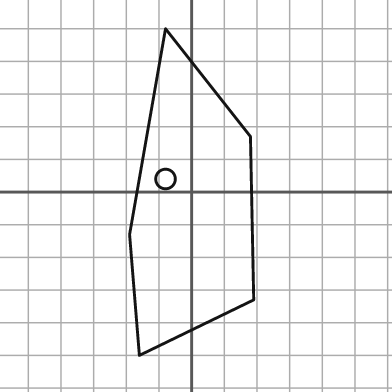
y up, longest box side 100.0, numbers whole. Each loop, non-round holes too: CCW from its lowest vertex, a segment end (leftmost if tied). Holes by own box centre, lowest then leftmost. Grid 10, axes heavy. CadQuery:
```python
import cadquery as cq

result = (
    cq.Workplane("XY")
    .moveTo(-16.0, -50.0)
    .lineTo(19.0, -33.0)
    .lineTo(18.0, 17.0)
    .lineTo(-8.0, 50.0)
    .lineTo(-19.0, -13.0)
    .close()
    .moveTo(-8.0, 4.0)
    .circle(3.0)
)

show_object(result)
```